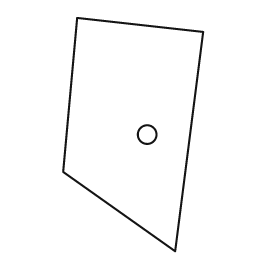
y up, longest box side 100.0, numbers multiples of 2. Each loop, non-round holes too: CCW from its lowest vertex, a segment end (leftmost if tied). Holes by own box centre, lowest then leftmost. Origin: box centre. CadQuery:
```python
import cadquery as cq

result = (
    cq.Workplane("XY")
    .moveTo(18.0, -50.0)
    .lineTo(30.0, 44.0)
    .lineTo(-24.0, 50.0)
    .lineTo(-30.0, -16.0)
    .close()
    .moveTo(6.0, 0.0)
    .circle(4.0)
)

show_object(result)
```